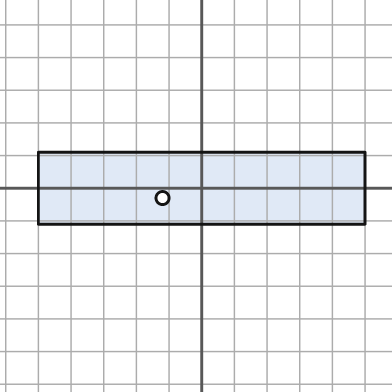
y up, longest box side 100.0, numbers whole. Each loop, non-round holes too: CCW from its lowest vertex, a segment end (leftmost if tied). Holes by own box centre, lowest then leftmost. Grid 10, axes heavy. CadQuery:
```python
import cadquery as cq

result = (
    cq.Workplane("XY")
    .moveTo(-50.0, -11.0)
    .lineTo(50.0, -11.0)
    .lineTo(50.0, 11.0)
    .lineTo(-50.0, 11.0)
    .close()
    .moveTo(-12.0, -3.0)
    .circle(2.0)
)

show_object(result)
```